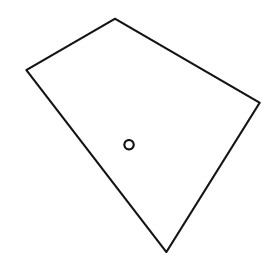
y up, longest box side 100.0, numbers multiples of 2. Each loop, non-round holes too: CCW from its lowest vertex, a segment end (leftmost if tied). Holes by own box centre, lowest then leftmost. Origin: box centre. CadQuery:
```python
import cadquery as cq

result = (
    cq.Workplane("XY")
    .moveTo(10.0, -50.0)
    .lineTo(50.0, 14.0)
    .lineTo(-12.0, 50.0)
    .lineTo(-50.0, 28.0)
    .close()
    .moveTo(-6.0, -4.0)
    .circle(2.0)
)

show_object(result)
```